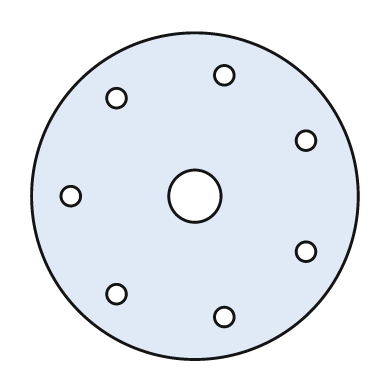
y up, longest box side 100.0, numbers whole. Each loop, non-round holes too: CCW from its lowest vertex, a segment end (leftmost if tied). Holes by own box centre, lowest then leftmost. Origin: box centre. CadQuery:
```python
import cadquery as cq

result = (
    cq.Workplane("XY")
    .moveTo(0.0, 0.0)
    .circle(50.0)
    .moveTo(9.0, -37.0)
    .circle(3.0)
    .moveTo(-24.0, -30.0)
    .circle(3.0)
    .moveTo(34.0, -17.0)
    .circle(3.0)
    .moveTo(-38.0, 0.0)
    .circle(3.0)
    .moveTo(0.0, 0.0)
    .circle(8.0)
    .moveTo(34.0, 17.0)
    .circle(3.0)
    .moveTo(-24.0, 30.0)
    .circle(3.0)
    .moveTo(9.0, 37.0)
    .circle(3.0)
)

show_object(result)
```